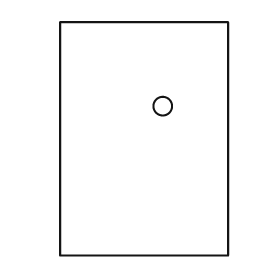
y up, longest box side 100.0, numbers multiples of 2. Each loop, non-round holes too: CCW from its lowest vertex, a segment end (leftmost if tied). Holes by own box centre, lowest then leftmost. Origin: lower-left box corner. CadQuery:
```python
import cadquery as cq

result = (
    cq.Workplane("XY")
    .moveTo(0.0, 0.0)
    .lineTo(72.0, 0.0)
    .lineTo(72.0, 100.0)
    .lineTo(0.0, 100.0)
    .close()
    .moveTo(44.0, 64.0)
    .circle(4.0)
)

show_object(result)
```